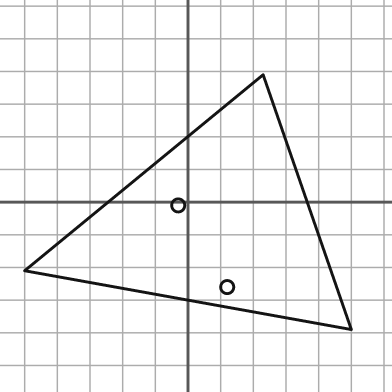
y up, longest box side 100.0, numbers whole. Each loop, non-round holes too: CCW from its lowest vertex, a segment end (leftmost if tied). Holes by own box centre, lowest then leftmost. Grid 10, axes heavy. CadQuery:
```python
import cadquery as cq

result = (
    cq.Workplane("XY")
    .moveTo(50.0, -39.0)
    .lineTo(23.0, 39.0)
    .lineTo(-50.0, -21.0)
    .close()
    .moveTo(12.0, -26.0)
    .circle(2.0)
    .moveTo(-3.0, -1.0)
    .circle(2.0)
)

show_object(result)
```